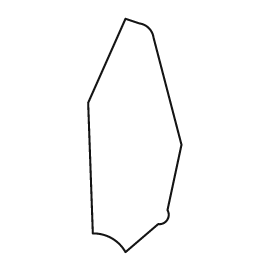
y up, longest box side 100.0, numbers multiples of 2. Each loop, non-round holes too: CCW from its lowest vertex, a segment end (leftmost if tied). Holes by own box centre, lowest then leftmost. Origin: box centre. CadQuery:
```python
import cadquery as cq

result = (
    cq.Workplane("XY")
    .moveTo(-4.0, -50.0)
    .lineTo(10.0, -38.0)
    .threePointArc((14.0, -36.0), (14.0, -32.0))
    .lineTo(20.0, -4.0)
    .lineTo(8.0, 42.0)
    .threePointArc((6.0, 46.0), (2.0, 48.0))
    .lineTo(-4.0, 50.0)
    .lineTo(-20.0, 14.0)
    .lineTo(-18.0, -42.0)
    .threePointArc((-10.0, -44.0), (-4.0, -50.0))
    .close()
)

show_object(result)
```